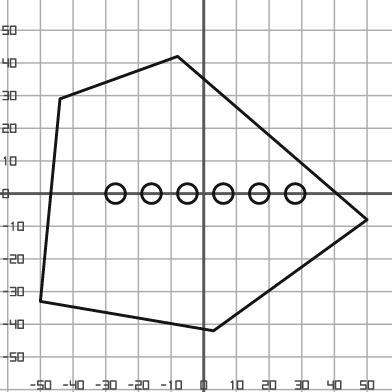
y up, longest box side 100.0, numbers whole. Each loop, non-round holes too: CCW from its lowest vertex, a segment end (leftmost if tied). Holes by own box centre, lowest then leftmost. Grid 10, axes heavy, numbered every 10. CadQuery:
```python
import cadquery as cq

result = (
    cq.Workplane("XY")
    .moveTo(3.0, -42.0)
    .lineTo(50.0, -8.0)
    .lineTo(-8.0, 42.0)
    .lineTo(-44.0, 29.0)
    .lineTo(-50.0, -33.0)
    .close()
    .moveTo(-27.0, 0.0)
    .circle(3.0)
    .moveTo(-16.0, 0.0)
    .circle(3.0)
    .moveTo(-5.0, 0.0)
    .circle(3.0)
    .moveTo(6.0, 0.0)
    .circle(3.0)
    .moveTo(17.0, 0.0)
    .circle(3.0)
    .moveTo(28.0, 0.0)
    .circle(3.0)
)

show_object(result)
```